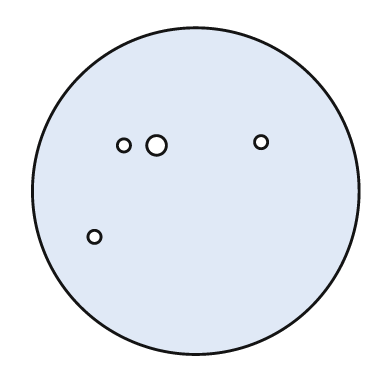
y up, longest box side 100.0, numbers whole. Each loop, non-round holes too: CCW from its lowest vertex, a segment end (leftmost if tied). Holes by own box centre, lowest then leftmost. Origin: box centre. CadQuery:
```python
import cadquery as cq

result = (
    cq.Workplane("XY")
    .moveTo(0.0, 0.0)
    .circle(50.0)
    .moveTo(-31.0, -14.0)
    .circle(2.0)
    .moveTo(-22.0, 14.0)
    .circle(2.0)
    .moveTo(-12.0, 14.0)
    .circle(3.0)
    .moveTo(20.0, 15.0)
    .circle(2.0)
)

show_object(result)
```